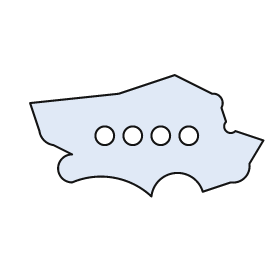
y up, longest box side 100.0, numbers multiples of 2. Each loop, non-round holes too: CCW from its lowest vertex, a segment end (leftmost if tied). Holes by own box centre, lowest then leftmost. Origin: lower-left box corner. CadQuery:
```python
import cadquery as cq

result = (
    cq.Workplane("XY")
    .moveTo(52.0, 0.0)
    .threePointArc((62.0, 10.0), (74.0, 2.0))
    .lineTo(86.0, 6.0)
    .threePointArc((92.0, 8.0), (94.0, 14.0))
    .lineTo(100.0, 24.0)
    .lineTo(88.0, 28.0)
    .threePointArc((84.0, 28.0), (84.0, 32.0))
    .lineTo(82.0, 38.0)
    .threePointArc((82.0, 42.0), (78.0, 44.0))
    .lineTo(62.0, 52.0)
    .lineTo(38.0, 44.0)
    .lineTo(0.0, 40.0)
    .lineTo(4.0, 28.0)
    .threePointArc((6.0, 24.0), (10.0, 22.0))
    .lineTo(18.0, 18.0)
    .threePointArc((12.0, 12.0), (18.0, 6.0))
    .threePointArc((36.0, 8.0), (52.0, 0.0))
    .close()
    .moveTo(32.0, 26.0)
    .circle(4.0)
    .moveTo(44.0, 26.0)
    .circle(4.0)
    .moveTo(56.0, 26.0)
    .circle(4.0)
    .moveTo(68.0, 26.0)
    .circle(4.0)
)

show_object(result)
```